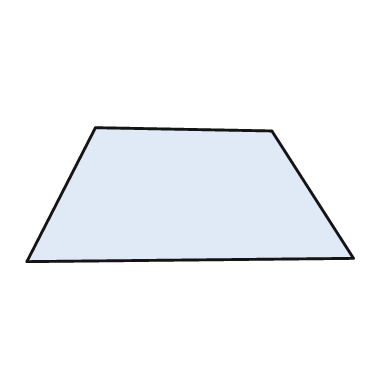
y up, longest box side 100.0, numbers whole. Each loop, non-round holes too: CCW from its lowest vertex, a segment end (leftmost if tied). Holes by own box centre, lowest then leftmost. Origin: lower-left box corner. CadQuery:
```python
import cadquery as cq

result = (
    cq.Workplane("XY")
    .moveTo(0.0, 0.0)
    .lineTo(100.0, 1.0)
    .lineTo(75.0, 40.0)
    .lineTo(21.0, 41.0)
    .close()
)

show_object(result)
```